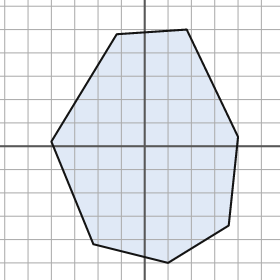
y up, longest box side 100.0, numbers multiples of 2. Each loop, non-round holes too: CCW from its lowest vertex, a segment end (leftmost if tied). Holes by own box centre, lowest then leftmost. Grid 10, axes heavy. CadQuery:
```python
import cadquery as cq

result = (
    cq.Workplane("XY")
    .moveTo(10.0, -50.0)
    .lineTo(36.0, -34.0)
    .lineTo(40.0, 4.0)
    .lineTo(18.0, 50.0)
    .lineTo(-12.0, 48.0)
    .lineTo(-40.0, 2.0)
    .lineTo(-22.0, -42.0)
    .close()
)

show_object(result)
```